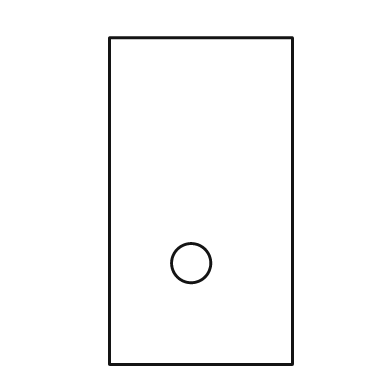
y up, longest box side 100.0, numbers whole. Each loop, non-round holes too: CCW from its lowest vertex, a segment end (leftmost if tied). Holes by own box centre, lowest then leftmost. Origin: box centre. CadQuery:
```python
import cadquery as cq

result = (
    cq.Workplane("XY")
    .moveTo(-28.0, -50.0)
    .lineTo(28.0, -50.0)
    .lineTo(28.0, 50.0)
    .lineTo(-28.0, 50.0)
    .close()
    .moveTo(-3.0, -19.0)
    .circle(6.0)
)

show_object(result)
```